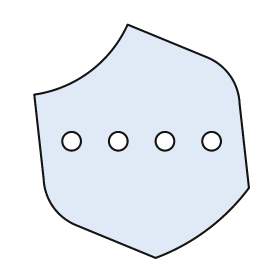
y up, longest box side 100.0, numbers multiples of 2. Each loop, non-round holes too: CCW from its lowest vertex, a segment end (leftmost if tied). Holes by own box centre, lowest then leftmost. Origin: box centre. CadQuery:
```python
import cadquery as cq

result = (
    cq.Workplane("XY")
    .moveTo(6.0, -50.0)
    .threePointArc((28.0, -38.0), (46.0, -20.0))
    .lineTo(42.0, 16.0)
    .threePointArc((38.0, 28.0), (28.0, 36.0))
    .lineTo(-6.0, 50.0)
    .threePointArc((-22.0, 30.0), (-46.0, 20.0))
    .lineTo(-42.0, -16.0)
    .threePointArc((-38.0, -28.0), (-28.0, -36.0))
    .close()
    .moveTo(-30.0, 0.0)
    .circle(4.0)
    .moveTo(-10.0, 0.0)
    .circle(4.0)
    .moveTo(10.0, 0.0)
    .circle(4.0)
    .moveTo(30.0, 0.0)
    .circle(4.0)
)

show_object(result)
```